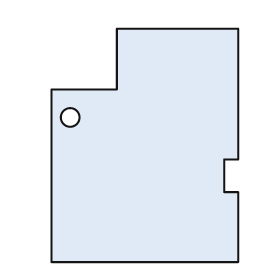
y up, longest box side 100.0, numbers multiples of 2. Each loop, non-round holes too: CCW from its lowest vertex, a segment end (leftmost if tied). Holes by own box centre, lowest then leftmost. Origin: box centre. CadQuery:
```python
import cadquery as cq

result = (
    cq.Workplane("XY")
    .moveTo(-40.0, -50.0)
    .lineTo(40.0, -50.0)
    .lineTo(40.0, -20.0)
    .lineTo(34.0, -20.0)
    .lineTo(34.0, -6.0)
    .lineTo(40.0, -6.0)
    .lineTo(40.0, 50.0)
    .lineTo(-12.0, 50.0)
    .lineTo(-12.0, 24.0)
    .lineTo(-40.0, 24.0)
    .close()
    .moveTo(-32.0, 12.0)
    .circle(4.0)
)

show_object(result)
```